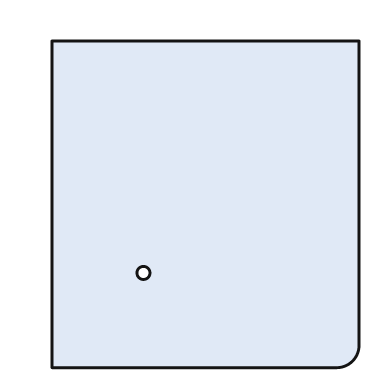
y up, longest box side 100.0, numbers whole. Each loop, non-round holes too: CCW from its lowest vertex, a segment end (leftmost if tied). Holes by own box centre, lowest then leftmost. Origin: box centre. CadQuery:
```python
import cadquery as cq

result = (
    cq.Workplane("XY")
    .moveTo(-47.0, -50.0)
    .lineTo(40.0, -50.0)
    .threePointArc((45.0, -48.0), (47.0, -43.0))
    .lineTo(47.0, 50.0)
    .lineTo(-47.0, 50.0)
    .close()
    .moveTo(-19.0, -21.0)
    .circle(2.0)
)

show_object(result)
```